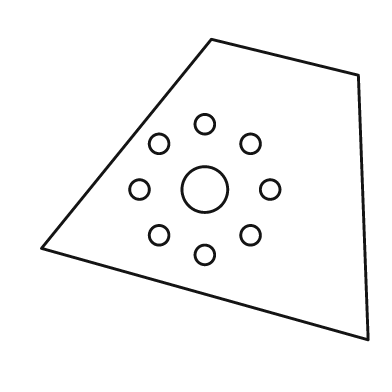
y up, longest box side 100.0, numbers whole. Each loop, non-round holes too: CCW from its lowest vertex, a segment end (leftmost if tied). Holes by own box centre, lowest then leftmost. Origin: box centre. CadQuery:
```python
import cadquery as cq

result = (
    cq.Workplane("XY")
    .moveTo(50.0, -46.0)
    .lineTo(47.0, 35.0)
    .lineTo(2.0, 46.0)
    .lineTo(-50.0, -18.0)
    .close()
    .moveTo(0.0, -20.0)
    .circle(3.0)
    .moveTo(-14.0, -14.0)
    .circle(3.0)
    .moveTo(14.0, -14.0)
    .circle(3.0)
    .moveTo(-20.0, 0.0)
    .circle(3.0)
    .moveTo(0.0, 0.0)
    .circle(7.0)
    .moveTo(20.0, 0.0)
    .circle(3.0)
    .moveTo(-14.0, 14.0)
    .circle(3.0)
    .moveTo(14.0, 14.0)
    .circle(3.0)
    .moveTo(0.0, 20.0)
    .circle(3.0)
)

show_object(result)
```